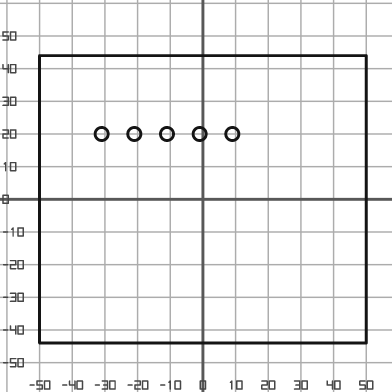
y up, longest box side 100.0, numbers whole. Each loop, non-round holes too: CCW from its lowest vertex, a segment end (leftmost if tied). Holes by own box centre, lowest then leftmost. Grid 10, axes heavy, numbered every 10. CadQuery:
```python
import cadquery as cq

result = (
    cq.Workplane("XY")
    .moveTo(-50.0, -44.0)
    .lineTo(50.0, -44.0)
    .lineTo(50.0, 44.0)
    .lineTo(-50.0, 44.0)
    .close()
    .moveTo(-31.0, 20.0)
    .circle(2.0)
    .moveTo(-21.0, 20.0)
    .circle(2.0)
    .moveTo(-11.0, 20.0)
    .circle(2.0)
    .moveTo(-1.0, 20.0)
    .circle(2.0)
    .moveTo(9.0, 20.0)
    .circle(2.0)
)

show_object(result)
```